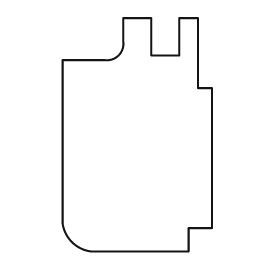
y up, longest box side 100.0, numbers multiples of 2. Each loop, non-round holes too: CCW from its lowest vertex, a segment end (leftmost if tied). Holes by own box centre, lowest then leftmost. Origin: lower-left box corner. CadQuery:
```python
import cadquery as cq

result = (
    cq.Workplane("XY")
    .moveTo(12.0, 0.0)
    .lineTo(54.0, 0.0)
    .lineTo(54.0, 10.0)
    .lineTo(64.0, 10.0)
    .lineTo(64.0, 70.0)
    .lineTo(58.0, 70.0)
    .lineTo(58.0, 100.0)
    .lineTo(50.0, 100.0)
    .lineTo(50.0, 84.0)
    .lineTo(38.0, 84.0)
    .lineTo(38.0, 100.0)
    .lineTo(26.0, 100.0)
    .lineTo(26.0, 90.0)
    .threePointArc((24.0, 84.0), (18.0, 82.0))
    .lineTo(0.0, 82.0)
    .lineTo(0.0, 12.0)
    .threePointArc((4.0, 4.0), (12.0, 0.0))
    .close()
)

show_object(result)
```